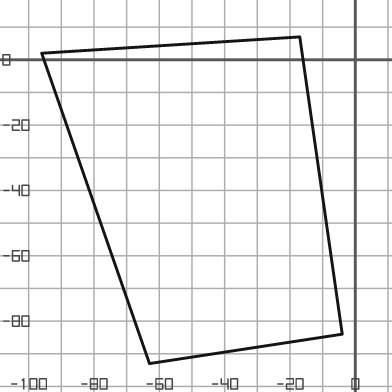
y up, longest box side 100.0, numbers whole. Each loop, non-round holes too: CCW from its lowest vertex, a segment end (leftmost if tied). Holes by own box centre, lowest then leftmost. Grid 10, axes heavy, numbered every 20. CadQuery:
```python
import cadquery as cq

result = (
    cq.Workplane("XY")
    .moveTo(-63.0, -93.0)
    .lineTo(-4.0, -84.0)
    .lineTo(-17.0, 7.0)
    .lineTo(-96.0, 2.0)
    .close()
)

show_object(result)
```